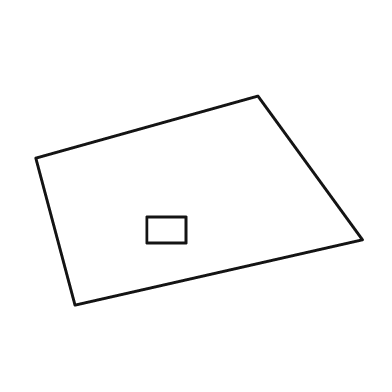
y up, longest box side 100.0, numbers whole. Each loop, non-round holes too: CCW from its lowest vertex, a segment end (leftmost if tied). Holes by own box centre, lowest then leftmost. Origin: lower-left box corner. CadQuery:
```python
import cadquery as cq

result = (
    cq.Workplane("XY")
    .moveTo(12.0, 0.0)
    .lineTo(100.0, 20.0)
    .lineTo(68.0, 64.0)
    .lineTo(0.0, 45.0)
    .close()
    .moveTo(34.0, 19.0)
    .lineTo(46.0, 19.0)
    .lineTo(46.0, 27.0)
    .lineTo(34.0, 27.0)
    .close()
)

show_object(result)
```